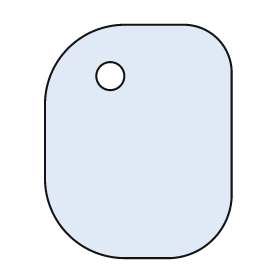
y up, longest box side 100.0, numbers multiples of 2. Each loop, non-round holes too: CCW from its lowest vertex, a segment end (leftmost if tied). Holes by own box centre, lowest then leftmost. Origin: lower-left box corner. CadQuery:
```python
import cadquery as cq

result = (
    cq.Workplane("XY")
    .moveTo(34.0, 0.0)
    .lineTo(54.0, 0.0)
    .threePointArc((72.0, 8.0), (80.0, 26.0))
    .lineTo(80.0, 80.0)
    .threePointArc((74.0, 94.0), (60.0, 100.0))
    .lineTo(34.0, 100.0)
    .threePointArc((10.0, 90.0), (0.0, 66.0))
    .lineTo(0.0, 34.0)
    .threePointArc((10.0, 10.0), (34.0, 0.0))
    .close()
    .moveTo(28.0, 78.0)
    .circle(6.0)
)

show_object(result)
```